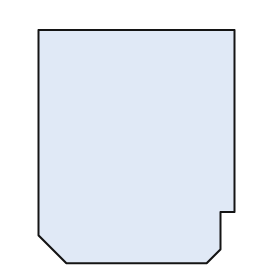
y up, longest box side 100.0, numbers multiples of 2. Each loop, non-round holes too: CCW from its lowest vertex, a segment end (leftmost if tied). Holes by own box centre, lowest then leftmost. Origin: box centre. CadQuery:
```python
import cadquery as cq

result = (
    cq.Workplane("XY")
    .moveTo(-30.0, -50.0)
    .lineTo(30.0, -50.0)
    .lineTo(36.0, -44.0)
    .lineTo(36.0, -28.0)
    .lineTo(42.0, -28.0)
    .lineTo(42.0, 50.0)
    .lineTo(-42.0, 50.0)
    .lineTo(-42.0, -38.0)
    .close()
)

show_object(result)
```